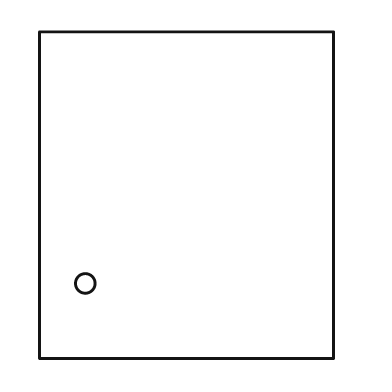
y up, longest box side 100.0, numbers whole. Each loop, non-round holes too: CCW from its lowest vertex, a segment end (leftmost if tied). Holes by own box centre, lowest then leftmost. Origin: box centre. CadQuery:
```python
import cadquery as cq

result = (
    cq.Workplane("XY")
    .moveTo(-45.0, -50.0)
    .lineTo(45.0, -50.0)
    .lineTo(45.0, 50.0)
    .lineTo(-45.0, 50.0)
    .close()
    .moveTo(-31.0, -27.0)
    .circle(3.0)
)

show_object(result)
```